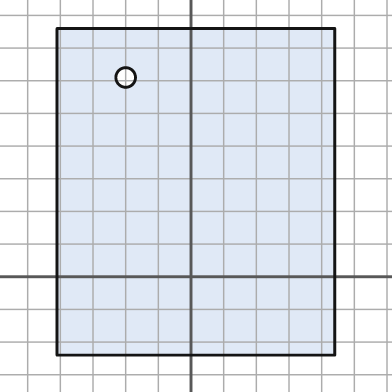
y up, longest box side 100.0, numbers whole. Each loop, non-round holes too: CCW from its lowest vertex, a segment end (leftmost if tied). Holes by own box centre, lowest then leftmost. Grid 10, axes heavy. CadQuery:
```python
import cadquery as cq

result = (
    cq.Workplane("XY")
    .moveTo(-41.0, -24.0)
    .lineTo(44.0, -24.0)
    .lineTo(44.0, 76.0)
    .lineTo(-41.0, 76.0)
    .close()
    .moveTo(-20.0, 61.0)
    .circle(3.0)
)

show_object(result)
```